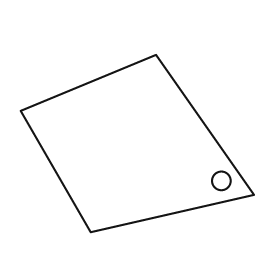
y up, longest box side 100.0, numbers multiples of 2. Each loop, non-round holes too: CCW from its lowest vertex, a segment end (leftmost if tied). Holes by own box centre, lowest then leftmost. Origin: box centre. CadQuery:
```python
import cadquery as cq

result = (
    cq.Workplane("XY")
    .moveTo(-20.0, -38.0)
    .lineTo(50.0, -22.0)
    .lineTo(8.0, 38.0)
    .lineTo(-50.0, 14.0)
    .close()
    .moveTo(36.0, -16.0)
    .circle(4.0)
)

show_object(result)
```